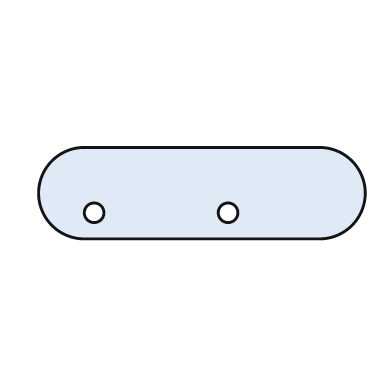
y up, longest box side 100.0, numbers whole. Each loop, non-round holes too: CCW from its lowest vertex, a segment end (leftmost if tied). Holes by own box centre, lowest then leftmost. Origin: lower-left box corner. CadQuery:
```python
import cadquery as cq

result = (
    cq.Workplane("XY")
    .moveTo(14.0, 0.0)
    .lineTo(86.0, 0.0)
    .threePointArc((100.0, 14.0), (86.0, 28.0))
    .lineTo(14.0, 28.0)
    .threePointArc((0.0, 14.0), (14.0, 0.0))
    .close()
    .moveTo(17.0, 8.0)
    .circle(3.0)
    .moveTo(58.0, 8.0)
    .circle(3.0)
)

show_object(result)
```